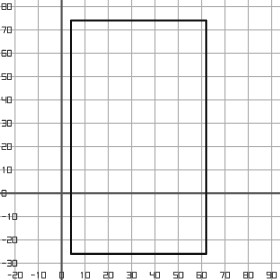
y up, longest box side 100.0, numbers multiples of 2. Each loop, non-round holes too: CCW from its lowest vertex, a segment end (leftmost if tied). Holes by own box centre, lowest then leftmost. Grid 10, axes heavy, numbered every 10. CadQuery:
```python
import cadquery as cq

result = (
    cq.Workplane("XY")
    .moveTo(4.0, -26.0)
    .lineTo(62.0, -26.0)
    .lineTo(62.0, 74.0)
    .lineTo(4.0, 74.0)
    .close()
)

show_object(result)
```